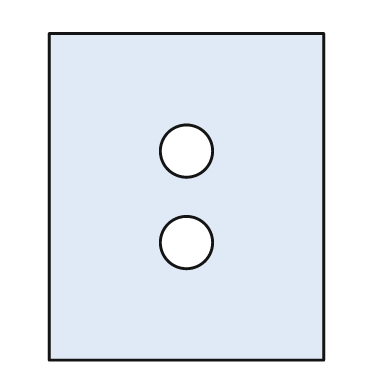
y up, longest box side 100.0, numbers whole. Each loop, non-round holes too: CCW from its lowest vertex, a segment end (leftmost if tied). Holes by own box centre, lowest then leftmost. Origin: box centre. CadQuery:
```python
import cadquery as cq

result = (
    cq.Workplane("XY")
    .moveTo(-42.0, -50.0)
    .lineTo(42.0, -50.0)
    .lineTo(42.0, 50.0)
    .lineTo(-42.0, 50.0)
    .close()
    .moveTo(0.0, -14.0)
    .circle(8.0)
    .moveTo(0.0, 14.0)
    .circle(8.0)
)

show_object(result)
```